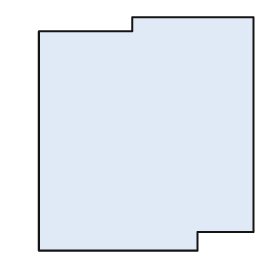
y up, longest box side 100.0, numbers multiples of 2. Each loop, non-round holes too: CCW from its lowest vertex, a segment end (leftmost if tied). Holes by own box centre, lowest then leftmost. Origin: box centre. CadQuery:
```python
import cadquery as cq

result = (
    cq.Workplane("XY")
    .moveTo(-46.0, -50.0)
    .lineTo(22.0, -50.0)
    .lineTo(22.0, -42.0)
    .lineTo(46.0, -42.0)
    .lineTo(46.0, 50.0)
    .lineTo(-6.0, 50.0)
    .lineTo(-6.0, 44.0)
    .lineTo(-46.0, 44.0)
    .close()
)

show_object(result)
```